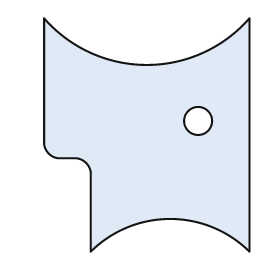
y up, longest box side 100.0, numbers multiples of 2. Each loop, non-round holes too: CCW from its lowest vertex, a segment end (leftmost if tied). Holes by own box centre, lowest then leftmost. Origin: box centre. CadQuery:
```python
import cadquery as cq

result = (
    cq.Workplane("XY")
    .moveTo(-24.0, -50.0)
    .threePointArc((10.0, -36.0), (44.0, -50.0))
    .lineTo(44.0, 50.0)
    .threePointArc((0.0, 30.0), (-44.0, 50.0))
    .lineTo(-44.0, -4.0)
    .threePointArc((-42.0, -8.0), (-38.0, -10.0))
    .lineTo(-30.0, -10.0)
    .threePointArc((-26.0, -12.0), (-24.0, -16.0))
    .close()
    .moveTo(22.0, 6.0)
    .circle(6.0)
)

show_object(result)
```